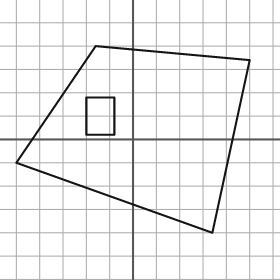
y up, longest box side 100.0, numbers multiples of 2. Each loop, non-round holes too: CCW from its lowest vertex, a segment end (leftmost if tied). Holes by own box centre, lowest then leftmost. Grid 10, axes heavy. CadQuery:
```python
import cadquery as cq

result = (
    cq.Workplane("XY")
    .moveTo(34.0, -40.0)
    .lineTo(50.0, 34.0)
    .lineTo(-16.0, 40.0)
    .lineTo(-50.0, -10.0)
    .close()
    .moveTo(-20.0, 2.0)
    .lineTo(-8.0, 2.0)
    .lineTo(-8.0, 18.0)
    .lineTo(-20.0, 18.0)
    .close()
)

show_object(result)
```